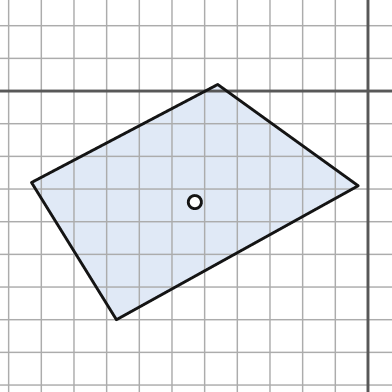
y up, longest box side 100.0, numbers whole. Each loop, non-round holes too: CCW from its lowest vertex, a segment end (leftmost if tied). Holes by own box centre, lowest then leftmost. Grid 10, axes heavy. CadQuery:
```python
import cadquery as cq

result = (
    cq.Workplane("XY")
    .moveTo(-77.0, -70.0)
    .lineTo(-3.0, -29.0)
    .lineTo(-46.0, 2.0)
    .lineTo(-103.0, -28.0)
    .close()
    .moveTo(-53.0, -34.0)
    .circle(2.0)
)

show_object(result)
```